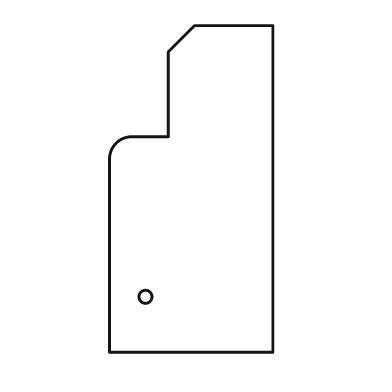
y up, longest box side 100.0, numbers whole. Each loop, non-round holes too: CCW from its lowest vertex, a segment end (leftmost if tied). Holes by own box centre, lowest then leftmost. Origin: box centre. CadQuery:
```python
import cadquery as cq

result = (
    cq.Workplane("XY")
    .moveTo(-25.0, -50.0)
    .lineTo(25.0, -50.0)
    .lineTo(25.0, 50.0)
    .lineTo(1.0, 50.0)
    .lineTo(-7.0, 42.0)
    .lineTo(-7.0, 16.0)
    .lineTo(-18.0, 16.0)
    .threePointArc((-23.0, 14.0), (-25.0, 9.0))
    .close()
    .moveTo(-14.0, -33.0)
    .circle(2.0)
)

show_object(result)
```